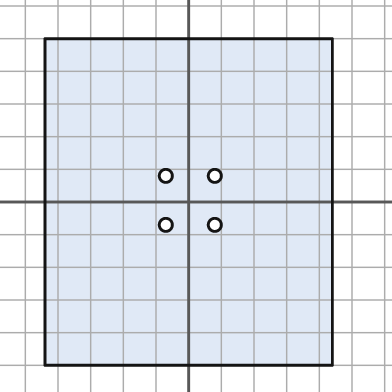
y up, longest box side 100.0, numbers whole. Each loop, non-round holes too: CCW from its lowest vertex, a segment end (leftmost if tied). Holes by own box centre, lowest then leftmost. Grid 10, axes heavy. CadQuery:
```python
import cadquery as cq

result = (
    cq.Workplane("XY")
    .moveTo(-44.0, -50.0)
    .lineTo(44.0, -50.0)
    .lineTo(44.0, 50.0)
    .lineTo(-44.0, 50.0)
    .close()
    .moveTo(-7.0, -7.0)
    .circle(2.0)
    .moveTo(8.0, -7.0)
    .circle(2.0)
    .moveTo(-7.0, 8.0)
    .circle(2.0)
    .moveTo(8.0, 8.0)
    .circle(2.0)
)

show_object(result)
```